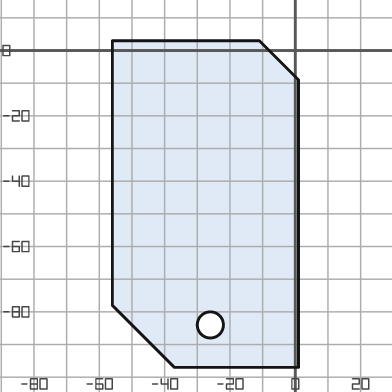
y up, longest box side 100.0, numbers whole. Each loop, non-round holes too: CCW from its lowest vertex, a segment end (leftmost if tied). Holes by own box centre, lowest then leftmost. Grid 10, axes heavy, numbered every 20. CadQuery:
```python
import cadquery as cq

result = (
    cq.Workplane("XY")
    .moveTo(-37.0, -97.0)
    .lineTo(1.0, -97.0)
    .lineTo(1.0, -9.0)
    .lineTo(-11.0, 3.0)
    .lineTo(-56.0, 3.0)
    .lineTo(-56.0, -78.0)
    .close()
    .moveTo(-26.0, -84.0)
    .circle(4.0)
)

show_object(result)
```